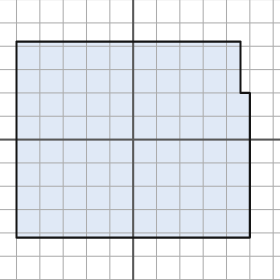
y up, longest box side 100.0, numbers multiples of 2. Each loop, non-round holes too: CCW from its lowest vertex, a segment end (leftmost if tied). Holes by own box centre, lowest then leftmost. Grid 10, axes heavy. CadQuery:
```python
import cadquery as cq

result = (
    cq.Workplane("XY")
    .moveTo(-50.0, -42.0)
    .lineTo(50.0, -42.0)
    .lineTo(50.0, 20.0)
    .lineTo(46.0, 20.0)
    .lineTo(46.0, 42.0)
    .lineTo(-50.0, 42.0)
    .close()
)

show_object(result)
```